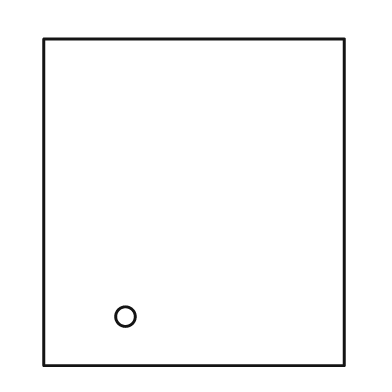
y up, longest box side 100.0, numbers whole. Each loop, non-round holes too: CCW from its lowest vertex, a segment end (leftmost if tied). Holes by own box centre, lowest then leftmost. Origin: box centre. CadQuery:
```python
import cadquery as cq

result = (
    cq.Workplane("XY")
    .moveTo(-46.0, -50.0)
    .lineTo(46.0, -50.0)
    .lineTo(46.0, 50.0)
    .lineTo(-46.0, 50.0)
    .close()
    .moveTo(-21.0, -35.0)
    .circle(3.0)
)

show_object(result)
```